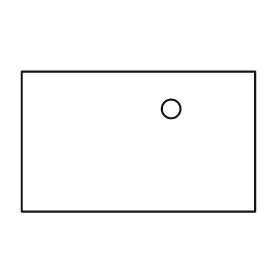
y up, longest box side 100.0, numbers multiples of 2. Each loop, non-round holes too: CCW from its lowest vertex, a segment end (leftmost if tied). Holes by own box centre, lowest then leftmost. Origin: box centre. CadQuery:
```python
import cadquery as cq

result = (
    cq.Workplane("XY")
    .moveTo(-50.0, -30.0)
    .lineTo(50.0, -30.0)
    .lineTo(50.0, 30.0)
    .lineTo(-50.0, 30.0)
    .close()
    .moveTo(14.0, 14.0)
    .circle(4.0)
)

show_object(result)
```